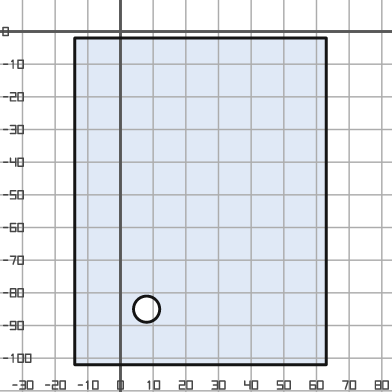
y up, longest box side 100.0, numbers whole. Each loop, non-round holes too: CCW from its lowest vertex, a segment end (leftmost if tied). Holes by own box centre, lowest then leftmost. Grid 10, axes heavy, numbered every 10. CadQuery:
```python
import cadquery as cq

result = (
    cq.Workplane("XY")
    .moveTo(-14.0, -102.0)
    .lineTo(63.0, -102.0)
    .lineTo(63.0, -2.0)
    .lineTo(-14.0, -2.0)
    .close()
    .moveTo(8.0, -85.0)
    .circle(4.0)
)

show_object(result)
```